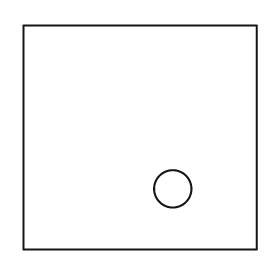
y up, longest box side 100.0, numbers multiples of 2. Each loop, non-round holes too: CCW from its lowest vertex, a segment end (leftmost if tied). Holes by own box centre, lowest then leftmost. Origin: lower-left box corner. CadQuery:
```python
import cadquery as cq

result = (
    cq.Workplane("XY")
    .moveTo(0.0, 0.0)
    .lineTo(100.0, 0.0)
    .lineTo(100.0, 96.0)
    .lineTo(0.0, 96.0)
    .close()
    .moveTo(64.0, 26.0)
    .circle(8.0)
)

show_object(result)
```